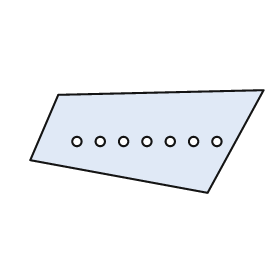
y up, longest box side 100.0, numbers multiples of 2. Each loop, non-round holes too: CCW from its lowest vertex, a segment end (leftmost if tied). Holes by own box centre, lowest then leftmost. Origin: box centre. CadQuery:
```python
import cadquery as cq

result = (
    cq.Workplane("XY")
    .moveTo(26.0, -22.0)
    .lineTo(50.0, 22.0)
    .lineTo(-38.0, 20.0)
    .lineTo(-50.0, -8.0)
    .close()
    .moveTo(-30.0, 0.0)
    .circle(2.0)
    .moveTo(-20.0, 0.0)
    .circle(2.0)
    .moveTo(-10.0, 0.0)
    .circle(2.0)
    .moveTo(0.0, 0.0)
    .circle(2.0)
    .moveTo(10.0, 0.0)
    .circle(2.0)
    .moveTo(20.0, 0.0)
    .circle(2.0)
    .moveTo(30.0, 0.0)
    .circle(2.0)
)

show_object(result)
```